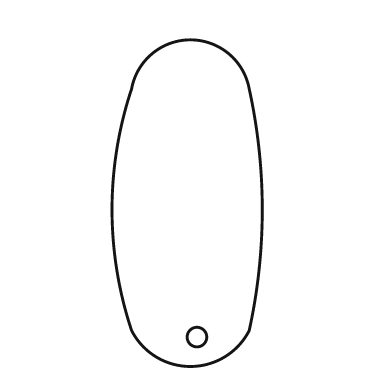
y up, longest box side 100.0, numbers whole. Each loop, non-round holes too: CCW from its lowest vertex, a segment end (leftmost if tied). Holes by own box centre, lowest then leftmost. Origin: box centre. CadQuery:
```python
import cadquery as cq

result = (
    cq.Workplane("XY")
    .moveTo(-17.0, -39.0)
    .threePointArc((1.0, -50.0), (19.0, -39.0))
    .threePointArc((23.0, -2.0), (19.0, 35.0))
    .threePointArc((1.0, 50.0), (-17.0, 35.0))
    .threePointArc((-23.0, -2.0), (-17.0, -39.0))
    .close()
    .moveTo(3.0, -41.0)
    .circle(3.0)
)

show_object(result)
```